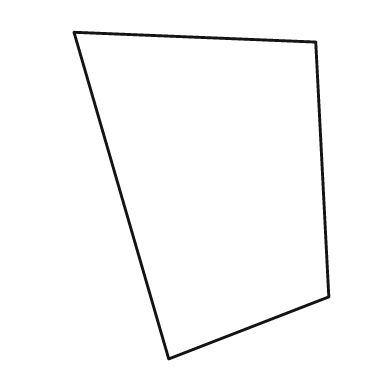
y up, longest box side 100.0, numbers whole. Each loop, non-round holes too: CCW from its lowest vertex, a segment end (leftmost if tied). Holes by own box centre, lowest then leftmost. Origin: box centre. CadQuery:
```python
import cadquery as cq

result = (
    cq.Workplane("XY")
    .moveTo(-10.0, -50.0)
    .lineTo(39.0, -31.0)
    .lineTo(35.0, 47.0)
    .lineTo(-39.0, 50.0)
    .close()
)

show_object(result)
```